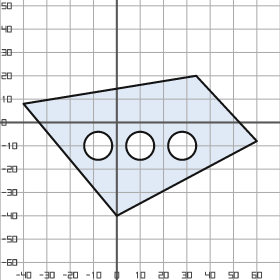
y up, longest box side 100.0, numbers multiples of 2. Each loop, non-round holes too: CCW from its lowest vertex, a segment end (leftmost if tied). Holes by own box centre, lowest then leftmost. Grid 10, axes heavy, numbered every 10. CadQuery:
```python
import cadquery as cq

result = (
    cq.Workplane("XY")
    .moveTo(0.0, -40.0)
    .lineTo(60.0, -8.0)
    .lineTo(34.0, 20.0)
    .lineTo(-40.0, 8.0)
    .close()
    .moveTo(-8.0, -10.0)
    .circle(6.0)
    .moveTo(10.0, -10.0)
    .circle(6.0)
    .moveTo(28.0, -10.0)
    .circle(6.0)
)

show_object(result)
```